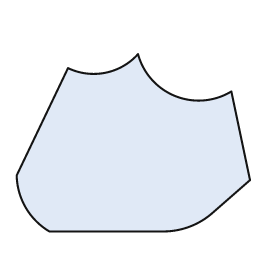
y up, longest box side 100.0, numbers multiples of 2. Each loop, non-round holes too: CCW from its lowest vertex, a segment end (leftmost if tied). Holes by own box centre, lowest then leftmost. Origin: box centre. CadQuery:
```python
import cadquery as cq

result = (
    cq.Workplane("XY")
    .moveTo(-36.0, -38.0)
    .lineTo(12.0, -38.0)
    .threePointArc((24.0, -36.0), (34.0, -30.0))
    .lineTo(50.0, -16.0)
    .lineTo(42.0, 22.0)
    .threePointArc((18.0, 20.0), (2.0, 38.0))
    .threePointArc((-12.0, 30.0), (-28.0, 32.0))
    .lineTo(-50.0, -14.0)
    .threePointArc((-46.0, -28.0), (-36.0, -38.0))
    .close()
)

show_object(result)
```